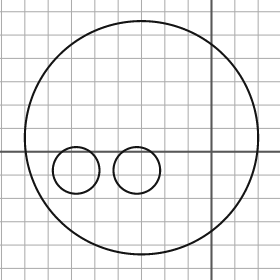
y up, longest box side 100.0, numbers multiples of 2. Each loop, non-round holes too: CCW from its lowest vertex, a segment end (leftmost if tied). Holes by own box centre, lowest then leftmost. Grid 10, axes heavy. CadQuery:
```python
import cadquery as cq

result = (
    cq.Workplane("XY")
    .moveTo(-30.0, 6.0)
    .circle(50.0)
    .moveTo(-58.0, -8.0)
    .circle(10.0)
    .moveTo(-32.0, -8.0)
    .circle(10.0)
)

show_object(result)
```